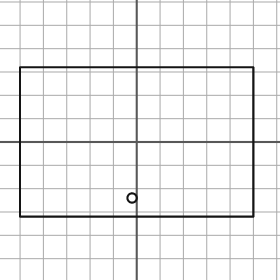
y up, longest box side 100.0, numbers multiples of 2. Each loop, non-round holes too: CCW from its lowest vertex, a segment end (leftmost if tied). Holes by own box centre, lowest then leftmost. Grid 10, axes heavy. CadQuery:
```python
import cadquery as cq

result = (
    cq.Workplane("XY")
    .moveTo(-50.0, -32.0)
    .lineTo(50.0, -32.0)
    .lineTo(50.0, 32.0)
    .lineTo(-50.0, 32.0)
    .close()
    .moveTo(-2.0, -24.0)
    .circle(2.0)
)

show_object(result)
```